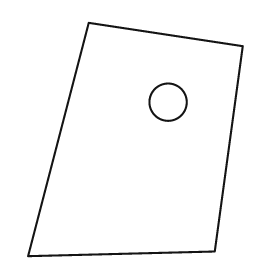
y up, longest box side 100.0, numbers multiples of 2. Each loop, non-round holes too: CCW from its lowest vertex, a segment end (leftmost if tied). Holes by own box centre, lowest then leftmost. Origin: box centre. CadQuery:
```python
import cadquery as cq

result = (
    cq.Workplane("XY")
    .moveTo(-46.0, -50.0)
    .lineTo(34.0, -48.0)
    .lineTo(46.0, 40.0)
    .lineTo(-20.0, 50.0)
    .close()
    .moveTo(14.0, 16.0)
    .circle(8.0)
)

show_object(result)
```